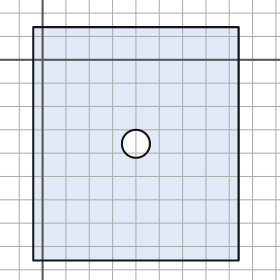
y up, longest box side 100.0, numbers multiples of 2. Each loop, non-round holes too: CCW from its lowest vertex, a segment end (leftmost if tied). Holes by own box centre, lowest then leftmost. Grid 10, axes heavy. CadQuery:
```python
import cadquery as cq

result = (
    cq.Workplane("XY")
    .moveTo(-4.0, -86.0)
    .lineTo(84.0, -86.0)
    .lineTo(84.0, 14.0)
    .lineTo(-4.0, 14.0)
    .close()
    .moveTo(40.0, -36.0)
    .circle(6.0)
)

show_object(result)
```